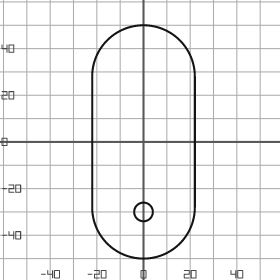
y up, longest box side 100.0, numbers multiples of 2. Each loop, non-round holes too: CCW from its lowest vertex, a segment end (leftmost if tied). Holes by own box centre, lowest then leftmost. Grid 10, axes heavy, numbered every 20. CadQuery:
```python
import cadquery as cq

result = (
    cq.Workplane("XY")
    .moveTo(-22.0, -28.0)
    .threePointArc((0.0, -50.0), (22.0, -28.0))
    .lineTo(22.0, 28.0)
    .threePointArc((0.0, 50.0), (-22.0, 28.0))
    .close()
    .moveTo(0.0, -30.0)
    .circle(4.0)
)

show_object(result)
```